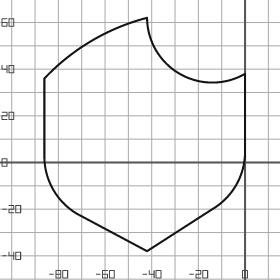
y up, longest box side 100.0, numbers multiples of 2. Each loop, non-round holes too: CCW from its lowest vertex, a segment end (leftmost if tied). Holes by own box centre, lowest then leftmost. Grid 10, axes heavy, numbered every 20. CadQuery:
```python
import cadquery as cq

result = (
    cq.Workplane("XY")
    .moveTo(-42.0, -38.0)
    .lineTo(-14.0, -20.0)
    .threePointArc((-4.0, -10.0), (0.0, 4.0))
    .lineTo(0.0, 38.0)
    .threePointArc((-28.0, 38.0), (-42.0, 62.0))
    .threePointArc((-66.0, 52.0), (-86.0, 36.0))
    .lineTo(-86.0, 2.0)
    .threePointArc((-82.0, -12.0), (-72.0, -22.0))
    .close()
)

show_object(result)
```